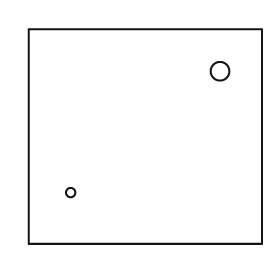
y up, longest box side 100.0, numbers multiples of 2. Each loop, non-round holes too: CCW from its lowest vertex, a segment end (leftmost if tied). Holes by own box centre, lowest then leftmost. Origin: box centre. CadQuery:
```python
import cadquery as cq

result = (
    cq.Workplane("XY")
    .moveTo(-50.0, -46.0)
    .lineTo(50.0, -46.0)
    .lineTo(50.0, 46.0)
    .lineTo(-50.0, 46.0)
    .close()
    .moveTo(-32.0, -24.0)
    .circle(2.0)
    .moveTo(32.0, 28.0)
    .circle(4.0)
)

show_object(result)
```